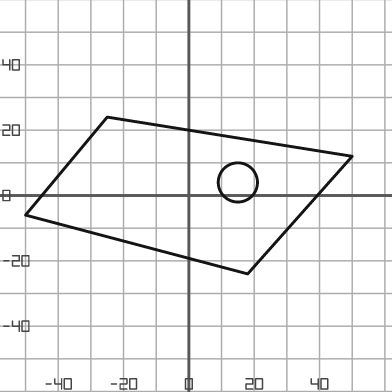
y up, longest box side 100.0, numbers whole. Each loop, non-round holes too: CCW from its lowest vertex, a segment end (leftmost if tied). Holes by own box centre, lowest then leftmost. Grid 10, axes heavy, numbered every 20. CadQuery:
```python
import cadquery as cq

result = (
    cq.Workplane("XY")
    .moveTo(18.0, -24.0)
    .lineTo(50.0, 12.0)
    .lineTo(-25.0, 24.0)
    .lineTo(-50.0, -6.0)
    .close()
    .moveTo(15.0, 4.0)
    .circle(6.0)
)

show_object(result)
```